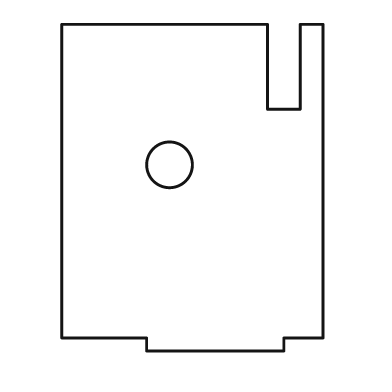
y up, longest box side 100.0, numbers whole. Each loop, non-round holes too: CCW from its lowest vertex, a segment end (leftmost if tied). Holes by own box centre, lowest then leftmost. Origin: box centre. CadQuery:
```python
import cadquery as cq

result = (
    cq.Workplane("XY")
    .moveTo(-14.0, -50.0)
    .lineTo(28.0, -50.0)
    .lineTo(28.0, -46.0)
    .lineTo(40.0, -46.0)
    .lineTo(40.0, 50.0)
    .lineTo(33.0, 50.0)
    .lineTo(33.0, 24.0)
    .lineTo(23.0, 24.0)
    .lineTo(23.0, 50.0)
    .lineTo(-40.0, 50.0)
    .lineTo(-40.0, -46.0)
    .lineTo(-14.0, -46.0)
    .close()
    .moveTo(-7.0, 7.0)
    .circle(7.0)
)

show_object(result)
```